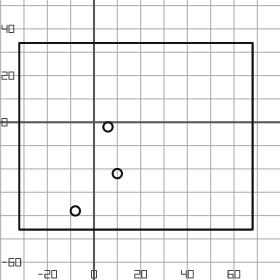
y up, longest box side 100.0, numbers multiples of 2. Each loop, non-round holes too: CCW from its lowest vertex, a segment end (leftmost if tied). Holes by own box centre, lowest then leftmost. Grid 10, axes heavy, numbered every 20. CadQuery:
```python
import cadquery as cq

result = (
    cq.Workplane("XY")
    .moveTo(-32.0, -46.0)
    .lineTo(68.0, -46.0)
    .lineTo(68.0, 34.0)
    .lineTo(-32.0, 34.0)
    .close()
    .moveTo(-8.0, -38.0)
    .circle(2.0)
    .moveTo(10.0, -22.0)
    .circle(2.0)
    .moveTo(6.0, -2.0)
    .circle(2.0)
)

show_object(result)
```